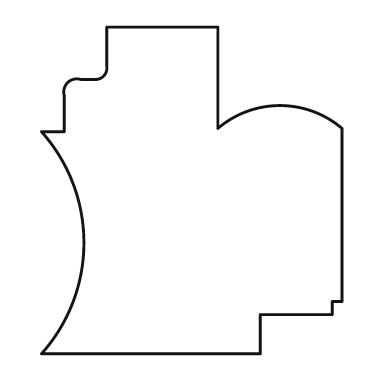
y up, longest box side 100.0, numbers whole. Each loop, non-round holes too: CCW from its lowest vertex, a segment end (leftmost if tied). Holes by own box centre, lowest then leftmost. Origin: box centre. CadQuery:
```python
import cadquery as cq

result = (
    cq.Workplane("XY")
    .moveTo(-46.0, -50.0)
    .lineTo(21.0, -50.0)
    .lineTo(21.0, -38.0)
    .lineTo(43.0, -38.0)
    .lineTo(43.0, -34.0)
    .lineTo(46.0, -34.0)
    .lineTo(46.0, 19.0)
    .threePointArc((27.0, 26.0), (8.0, 19.0))
    .lineTo(8.0, 50.0)
    .lineTo(-26.0, 50.0)
    .lineTo(-26.0, 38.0)
    .threePointArc((-27.0, 35.0), (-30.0, 34.0))
    .lineTo(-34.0, 34.0)
    .threePointArc((-38.0, 33.0), (-39.0, 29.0))
    .lineTo(-39.0, 18.0)
    .lineTo(-46.0, 18.0)
    .threePointArc((-33.0, -16.0), (-46.0, -50.0))
    .close()
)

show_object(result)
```